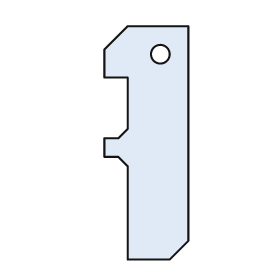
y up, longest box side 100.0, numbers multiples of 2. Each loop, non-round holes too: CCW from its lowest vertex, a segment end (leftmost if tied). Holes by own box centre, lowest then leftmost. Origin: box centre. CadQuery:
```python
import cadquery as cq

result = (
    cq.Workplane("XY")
    .moveTo(-8.0, -50.0)
    .lineTo(10.0, -50.0)
    .lineTo(18.0, -42.0)
    .lineTo(18.0, 50.0)
    .lineTo(-8.0, 50.0)
    .lineTo(-18.0, 40.0)
    .lineTo(-18.0, 28.0)
    .lineTo(-8.0, 28.0)
    .lineTo(-8.0, 6.0)
    .lineTo(-12.0, 2.0)
    .lineTo(-18.0, 2.0)
    .lineTo(-18.0, -6.0)
    .lineTo(-12.0, -6.0)
    .lineTo(-8.0, -10.0)
    .close()
    .moveTo(6.0, 38.0)
    .circle(4.0)
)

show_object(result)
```